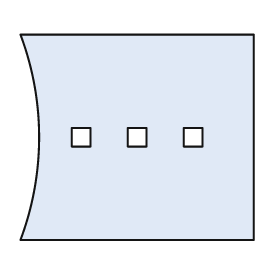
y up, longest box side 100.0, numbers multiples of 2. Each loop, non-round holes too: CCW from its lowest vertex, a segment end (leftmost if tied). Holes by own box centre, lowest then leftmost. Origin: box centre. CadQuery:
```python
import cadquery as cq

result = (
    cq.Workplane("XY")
    .moveTo(-50.0, -44.0)
    .lineTo(50.0, -44.0)
    .lineTo(50.0, 44.0)
    .lineTo(-50.0, 44.0)
    .threePointArc((-42.0, 0.0), (-50.0, -44.0))
    .close()
    .moveTo(-28.0, -4.0)
    .lineTo(-20.0, -4.0)
    .lineTo(-20.0, 4.0)
    .lineTo(-28.0, 4.0)
    .close()
    .moveTo(-4.0, -4.0)
    .lineTo(4.0, -4.0)
    .lineTo(4.0, 4.0)
    .lineTo(-4.0, 4.0)
    .close()
    .moveTo(20.0, -4.0)
    .lineTo(28.0, -4.0)
    .lineTo(28.0, 4.0)
    .lineTo(20.0, 4.0)
    .close()
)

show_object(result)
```